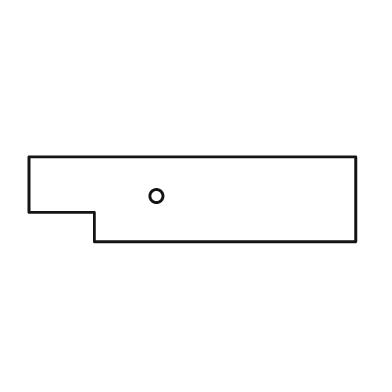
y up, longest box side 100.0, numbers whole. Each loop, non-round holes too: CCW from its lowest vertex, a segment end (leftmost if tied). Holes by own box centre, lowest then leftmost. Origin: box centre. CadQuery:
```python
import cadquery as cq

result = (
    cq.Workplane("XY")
    .moveTo(-30.0, -13.0)
    .lineTo(50.0, -13.0)
    .lineTo(50.0, 13.0)
    .lineTo(-50.0, 13.0)
    .lineTo(-50.0, -4.0)
    .lineTo(-30.0, -4.0)
    .close()
    .moveTo(-11.0, 1.0)
    .circle(2.0)
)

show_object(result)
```